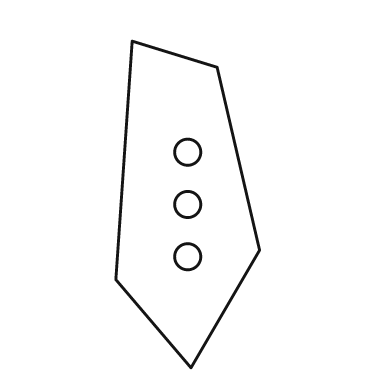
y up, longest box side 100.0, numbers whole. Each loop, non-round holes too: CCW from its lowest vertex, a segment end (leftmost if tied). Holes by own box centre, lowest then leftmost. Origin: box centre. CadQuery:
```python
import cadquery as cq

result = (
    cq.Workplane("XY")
    .moveTo(1.0, -50.0)
    .lineTo(22.0, -14.0)
    .lineTo(9.0, 42.0)
    .lineTo(-17.0, 50.0)
    .lineTo(-22.0, -23.0)
    .close()
    .moveTo(0.0, -16.0)
    .circle(4.0)
    .moveTo(0.0, 0.0)
    .circle(4.0)
    .moveTo(0.0, 16.0)
    .circle(4.0)
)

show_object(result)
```